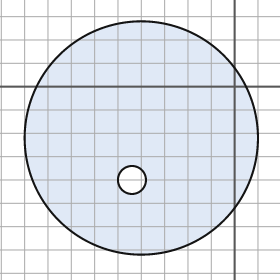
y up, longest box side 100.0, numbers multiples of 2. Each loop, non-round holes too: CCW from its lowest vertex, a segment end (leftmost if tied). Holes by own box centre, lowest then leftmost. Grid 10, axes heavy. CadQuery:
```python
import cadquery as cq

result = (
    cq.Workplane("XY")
    .moveTo(-40.0, -22.0)
    .circle(50.0)
    .moveTo(-44.0, -40.0)
    .circle(6.0)
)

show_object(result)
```